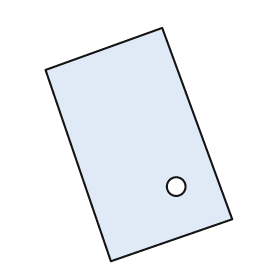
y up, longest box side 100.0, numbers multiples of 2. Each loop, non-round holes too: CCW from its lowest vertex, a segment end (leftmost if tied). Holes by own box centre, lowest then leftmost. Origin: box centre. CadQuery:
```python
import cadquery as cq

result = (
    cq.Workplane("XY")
    .moveTo(-12.0, -50.0)
    .lineTo(40.0, -32.0)
    .lineTo(10.0, 50.0)
    .lineTo(-40.0, 32.0)
    .close()
    .moveTo(16.0, -18.0)
    .circle(4.0)
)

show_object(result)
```